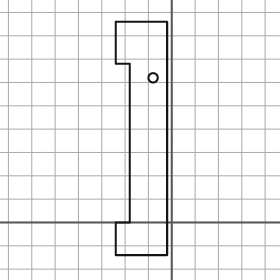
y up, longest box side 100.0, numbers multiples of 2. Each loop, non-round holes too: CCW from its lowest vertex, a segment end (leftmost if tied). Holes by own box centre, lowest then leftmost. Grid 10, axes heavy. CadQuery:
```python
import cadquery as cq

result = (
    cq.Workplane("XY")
    .moveTo(-24.0, -14.0)
    .lineTo(-2.0, -14.0)
    .lineTo(-2.0, 86.0)
    .lineTo(-24.0, 86.0)
    .lineTo(-24.0, 68.0)
    .lineTo(-18.0, 68.0)
    .lineTo(-18.0, 0.0)
    .lineTo(-24.0, 0.0)
    .close()
    .moveTo(-8.0, 62.0)
    .circle(2.0)
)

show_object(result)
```